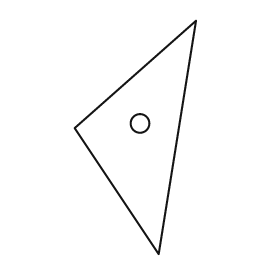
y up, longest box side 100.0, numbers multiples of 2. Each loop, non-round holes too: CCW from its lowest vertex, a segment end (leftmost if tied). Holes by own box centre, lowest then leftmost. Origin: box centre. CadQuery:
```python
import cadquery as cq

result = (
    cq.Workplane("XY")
    .moveTo(10.0, -50.0)
    .lineTo(26.0, 50.0)
    .lineTo(-26.0, 4.0)
    .close()
    .moveTo(2.0, 6.0)
    .circle(4.0)
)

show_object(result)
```